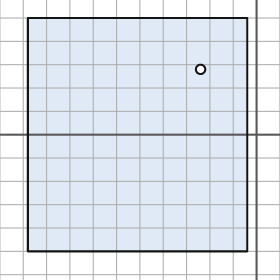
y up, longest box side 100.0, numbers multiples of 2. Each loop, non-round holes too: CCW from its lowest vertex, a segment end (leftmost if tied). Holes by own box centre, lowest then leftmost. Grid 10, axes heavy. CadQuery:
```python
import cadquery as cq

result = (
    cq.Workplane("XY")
    .moveTo(-98.0, -50.0)
    .lineTo(-4.0, -50.0)
    .lineTo(-4.0, 50.0)
    .lineTo(-98.0, 50.0)
    .close()
    .moveTo(-24.0, 28.0)
    .circle(2.0)
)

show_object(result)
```